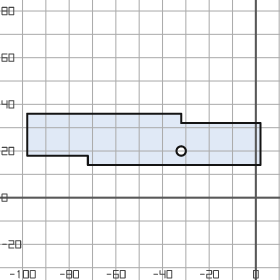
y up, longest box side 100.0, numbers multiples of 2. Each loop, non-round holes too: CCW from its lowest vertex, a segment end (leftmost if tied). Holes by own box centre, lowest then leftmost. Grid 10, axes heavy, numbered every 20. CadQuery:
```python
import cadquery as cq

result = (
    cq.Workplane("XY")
    .moveTo(-72.0, 14.0)
    .lineTo(2.0, 14.0)
    .lineTo(2.0, 32.0)
    .lineTo(-32.0, 32.0)
    .lineTo(-32.0, 36.0)
    .lineTo(-98.0, 36.0)
    .lineTo(-98.0, 18.0)
    .lineTo(-72.0, 18.0)
    .close()
    .moveTo(-32.0, 20.0)
    .circle(2.0)
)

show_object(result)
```